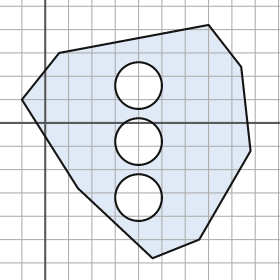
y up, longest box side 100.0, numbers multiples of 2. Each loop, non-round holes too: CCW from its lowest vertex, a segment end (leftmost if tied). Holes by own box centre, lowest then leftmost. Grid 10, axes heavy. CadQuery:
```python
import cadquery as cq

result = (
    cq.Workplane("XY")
    .moveTo(46.0, -58.0)
    .lineTo(66.0, -50.0)
    .lineTo(88.0, -12.0)
    .lineTo(84.0, 24.0)
    .lineTo(70.0, 42.0)
    .lineTo(6.0, 30.0)
    .lineTo(-10.0, 10.0)
    .lineTo(14.0, -28.0)
    .close()
    .moveTo(40.0, -32.0)
    .circle(10.0)
    .moveTo(40.0, -8.0)
    .circle(10.0)
    .moveTo(40.0, 16.0)
    .circle(10.0)
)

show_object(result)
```